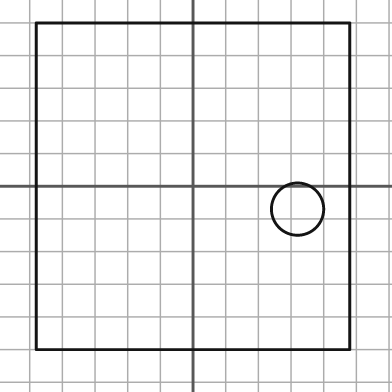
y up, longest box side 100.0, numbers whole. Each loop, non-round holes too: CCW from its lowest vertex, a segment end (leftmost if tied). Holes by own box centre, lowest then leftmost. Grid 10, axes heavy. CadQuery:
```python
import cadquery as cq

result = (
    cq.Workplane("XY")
    .moveTo(-48.0, -50.0)
    .lineTo(48.0, -50.0)
    .lineTo(48.0, 50.0)
    .lineTo(-48.0, 50.0)
    .close()
    .moveTo(32.0, -7.0)
    .circle(8.0)
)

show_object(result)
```